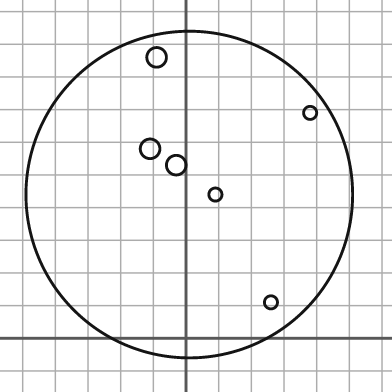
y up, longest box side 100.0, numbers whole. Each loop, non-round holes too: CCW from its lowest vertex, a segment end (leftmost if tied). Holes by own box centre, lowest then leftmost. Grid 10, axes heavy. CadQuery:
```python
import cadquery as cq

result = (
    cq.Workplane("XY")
    .moveTo(1.0, 44.0)
    .circle(50.0)
    .moveTo(26.0, 11.0)
    .circle(2.0)
    .moveTo(9.0, 44.0)
    .circle(2.0)
    .moveTo(-3.0, 53.0)
    .circle(3.0)
    .moveTo(-11.0, 58.0)
    .circle(3.0)
    .moveTo(38.0, 69.0)
    .circle(2.0)
    .moveTo(-9.0, 86.0)
    .circle(3.0)
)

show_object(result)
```